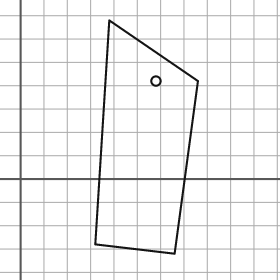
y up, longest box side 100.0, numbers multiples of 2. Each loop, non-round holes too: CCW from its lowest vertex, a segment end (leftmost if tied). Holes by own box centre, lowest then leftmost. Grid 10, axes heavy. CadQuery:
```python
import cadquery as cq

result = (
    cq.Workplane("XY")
    .moveTo(66.0, -32.0)
    .lineTo(76.0, 42.0)
    .lineTo(38.0, 68.0)
    .lineTo(32.0, -28.0)
    .close()
    .moveTo(58.0, 42.0)
    .circle(2.0)
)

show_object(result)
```